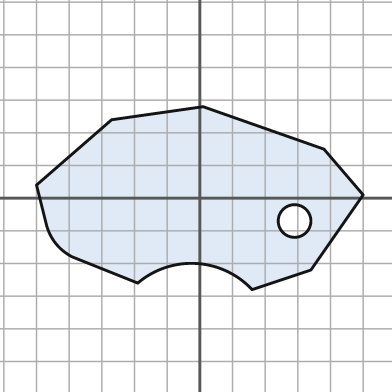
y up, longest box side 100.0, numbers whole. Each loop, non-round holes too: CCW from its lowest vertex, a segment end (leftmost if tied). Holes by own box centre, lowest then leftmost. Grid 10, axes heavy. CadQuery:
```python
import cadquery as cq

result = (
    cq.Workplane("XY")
    .moveTo(16.0, -28.0)
    .lineTo(34.0, -22.0)
    .lineTo(50.0, 1.0)
    .lineTo(38.0, 15.0)
    .lineTo(1.0, 28.0)
    .lineTo(-27.0, 24.0)
    .lineTo(-50.0, 4.0)
    .lineTo(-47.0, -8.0)
    .threePointArc((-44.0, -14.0), (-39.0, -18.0))
    .lineTo(-19.0, -26.0)
    .threePointArc((-1.0, -20.0), (16.0, -28.0))
    .close()
    .moveTo(29.0, -7.0)
    .circle(5.0)
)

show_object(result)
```